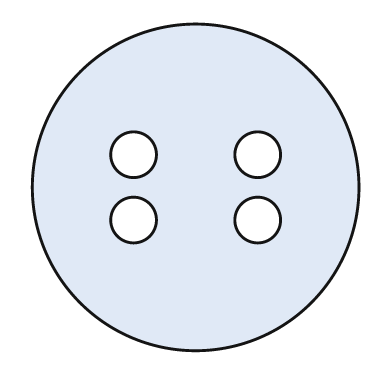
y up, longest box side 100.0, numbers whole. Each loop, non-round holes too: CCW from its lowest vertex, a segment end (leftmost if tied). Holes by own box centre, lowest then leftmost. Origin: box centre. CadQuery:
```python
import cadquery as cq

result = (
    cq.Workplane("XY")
    .moveTo(0.0, 0.0)
    .circle(50.0)
    .moveTo(-19.0, -10.0)
    .circle(7.0)
    .moveTo(19.0, -10.0)
    .circle(7.0)
    .moveTo(-19.0, 10.0)
    .circle(7.0)
    .moveTo(19.0, 10.0)
    .circle(7.0)
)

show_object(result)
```